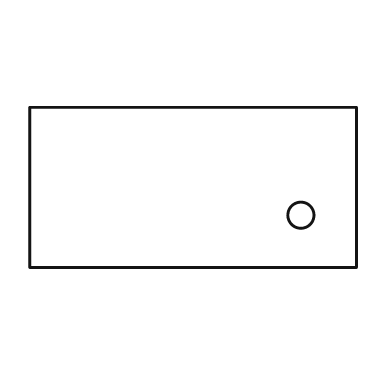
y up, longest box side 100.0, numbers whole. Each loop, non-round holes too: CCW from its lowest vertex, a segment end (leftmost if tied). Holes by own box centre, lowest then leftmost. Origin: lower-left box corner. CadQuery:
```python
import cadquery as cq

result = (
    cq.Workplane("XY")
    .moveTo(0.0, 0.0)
    .lineTo(100.0, 0.0)
    .lineTo(100.0, 49.0)
    .lineTo(0.0, 49.0)
    .close()
    .moveTo(83.0, 16.0)
    .circle(4.0)
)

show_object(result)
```